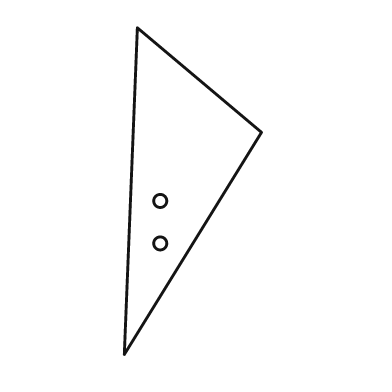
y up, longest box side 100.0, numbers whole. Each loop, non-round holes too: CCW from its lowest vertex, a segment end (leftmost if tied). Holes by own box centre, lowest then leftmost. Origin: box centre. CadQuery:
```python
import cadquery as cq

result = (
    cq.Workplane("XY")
    .moveTo(-21.0, -50.0)
    .lineTo(21.0, 18.0)
    .lineTo(-17.0, 50.0)
    .close()
    .moveTo(-10.0, -16.0)
    .circle(2.0)
    .moveTo(-10.0, -3.0)
    .circle(2.0)
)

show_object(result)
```